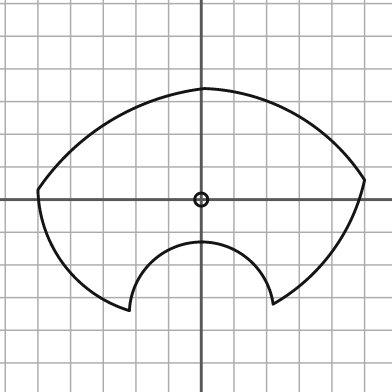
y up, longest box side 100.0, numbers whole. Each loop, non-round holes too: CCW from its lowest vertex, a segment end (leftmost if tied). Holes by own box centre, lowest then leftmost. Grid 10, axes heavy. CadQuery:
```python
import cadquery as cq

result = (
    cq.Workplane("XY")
    .moveTo(-22.0, -34.0)
    .threePointArc((-1.0, -13.0), (22.0, -32.0))
    .threePointArc((40.0, -16.0), (50.0, 6.0))
    .threePointArc((29.0, 26.0), (1.0, 34.0))
    .threePointArc((-28.0, 24.0), (-50.0, 3.0))
    .threePointArc((-42.0, -20.0), (-22.0, -34.0))
    .close()
    .moveTo(0.0, 0.0)
    .circle(2.0)
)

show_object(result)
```